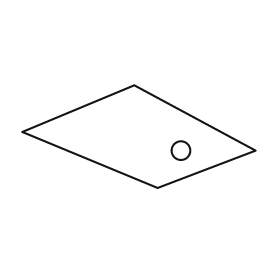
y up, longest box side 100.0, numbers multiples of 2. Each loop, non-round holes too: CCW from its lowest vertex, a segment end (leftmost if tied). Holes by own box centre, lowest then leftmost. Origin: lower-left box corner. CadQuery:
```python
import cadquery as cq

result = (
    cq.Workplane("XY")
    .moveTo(58.0, 0.0)
    .lineTo(100.0, 16.0)
    .lineTo(48.0, 44.0)
    .lineTo(0.0, 24.0)
    .close()
    .moveTo(68.0, 16.0)
    .circle(4.0)
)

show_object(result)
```